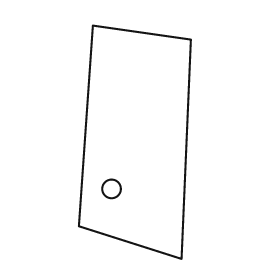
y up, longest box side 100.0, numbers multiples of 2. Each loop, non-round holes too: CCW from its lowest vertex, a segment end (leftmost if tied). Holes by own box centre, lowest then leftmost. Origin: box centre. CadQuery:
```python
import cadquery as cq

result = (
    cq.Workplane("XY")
    .moveTo(20.0, -50.0)
    .lineTo(24.0, 44.0)
    .lineTo(-18.0, 50.0)
    .lineTo(-24.0, -36.0)
    .close()
    .moveTo(-10.0, -20.0)
    .circle(4.0)
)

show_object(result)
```